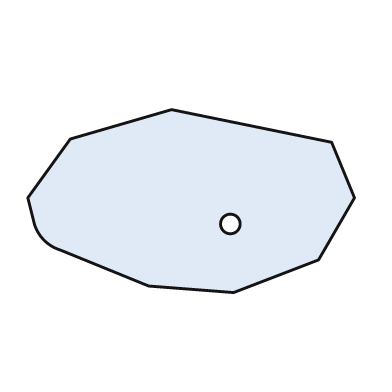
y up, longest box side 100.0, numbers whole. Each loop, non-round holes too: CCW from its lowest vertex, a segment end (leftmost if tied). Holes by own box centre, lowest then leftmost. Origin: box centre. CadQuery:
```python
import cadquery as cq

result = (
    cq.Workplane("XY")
    .moveTo(13.0, -28.0)
    .lineTo(39.0, -18.0)
    .lineTo(50.0, 1.0)
    .lineTo(43.0, 18.0)
    .lineTo(-6.0, 28.0)
    .lineTo(-37.0, 19.0)
    .lineTo(-50.0, 1.0)
    .lineTo(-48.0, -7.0)
    .threePointArc((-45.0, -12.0), (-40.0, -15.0))
    .lineTo(-13.0, -26.0)
    .close()
    .moveTo(12.0, -7.0)
    .circle(3.0)
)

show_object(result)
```